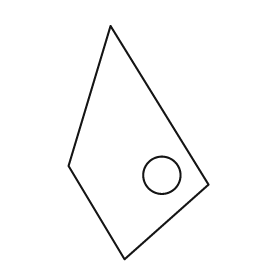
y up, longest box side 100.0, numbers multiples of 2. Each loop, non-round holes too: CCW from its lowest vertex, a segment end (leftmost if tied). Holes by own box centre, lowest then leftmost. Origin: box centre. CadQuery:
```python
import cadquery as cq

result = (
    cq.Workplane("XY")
    .moveTo(-6.0, -50.0)
    .lineTo(30.0, -18.0)
    .lineTo(-12.0, 50.0)
    .lineTo(-30.0, -10.0)
    .close()
    .moveTo(10.0, -14.0)
    .circle(8.0)
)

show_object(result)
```